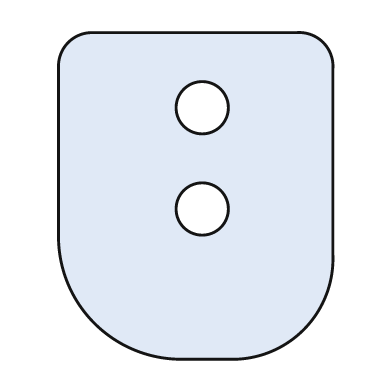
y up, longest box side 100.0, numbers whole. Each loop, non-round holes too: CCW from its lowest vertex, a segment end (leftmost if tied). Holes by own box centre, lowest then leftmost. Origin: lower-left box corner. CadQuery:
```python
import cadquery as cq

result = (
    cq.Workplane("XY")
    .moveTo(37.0, 0.0)
    .lineTo(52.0, 0.0)
    .threePointArc((75.0, 9.0), (84.0, 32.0))
    .lineTo(84.0, 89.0)
    .threePointArc((81.0, 97.0), (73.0, 100.0))
    .lineTo(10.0, 100.0)
    .threePointArc((3.0, 97.0), (0.0, 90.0))
    .lineTo(0.0, 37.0)
    .threePointArc((11.0, 11.0), (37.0, 0.0))
    .close()
    .moveTo(44.0, 46.0)
    .circle(8.0)
    .moveTo(44.0, 77.0)
    .circle(8.0)
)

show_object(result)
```